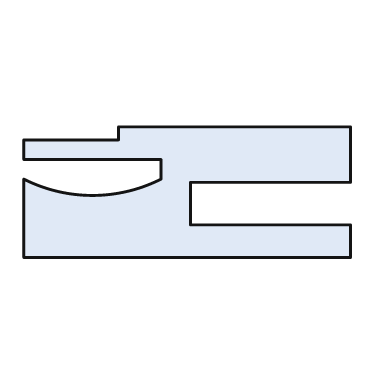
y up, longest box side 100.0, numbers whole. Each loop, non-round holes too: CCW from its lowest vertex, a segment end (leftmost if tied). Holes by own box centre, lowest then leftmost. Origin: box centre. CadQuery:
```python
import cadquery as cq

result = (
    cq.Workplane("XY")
    .moveTo(-50.0, -20.0)
    .lineTo(50.0, -20.0)
    .lineTo(50.0, -10.0)
    .lineTo(1.0, -10.0)
    .lineTo(1.0, 3.0)
    .lineTo(50.0, 3.0)
    .lineTo(50.0, 20.0)
    .lineTo(-21.0, 20.0)
    .lineTo(-21.0, 16.0)
    .lineTo(-50.0, 16.0)
    .lineTo(-50.0, 10.0)
    .lineTo(-8.0, 10.0)
    .lineTo(-8.0, 4.0)
    .threePointArc((-29.0, -1.0), (-50.0, 4.0))
    .close()
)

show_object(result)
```